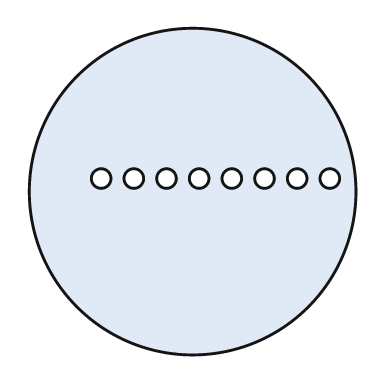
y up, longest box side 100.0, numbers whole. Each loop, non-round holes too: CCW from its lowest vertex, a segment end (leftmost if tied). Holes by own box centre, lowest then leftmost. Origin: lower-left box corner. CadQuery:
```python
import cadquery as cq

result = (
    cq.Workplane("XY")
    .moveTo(50.0, 50.0)
    .circle(50.0)
    .moveTo(22.0, 54.0)
    .circle(3.0)
    .moveTo(32.0, 54.0)
    .circle(3.0)
    .moveTo(42.0, 54.0)
    .circle(3.0)
    .moveTo(52.0, 54.0)
    .circle(3.0)
    .moveTo(62.0, 54.0)
    .circle(3.0)
    .moveTo(72.0, 54.0)
    .circle(3.0)
    .moveTo(82.0, 54.0)
    .circle(3.0)
    .moveTo(92.0, 54.0)
    .circle(3.0)
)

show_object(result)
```